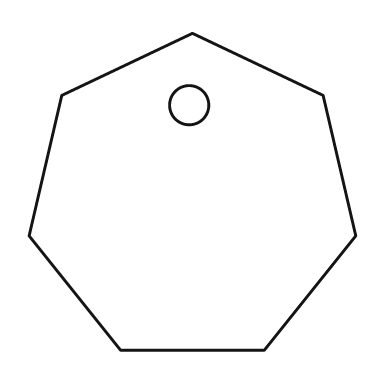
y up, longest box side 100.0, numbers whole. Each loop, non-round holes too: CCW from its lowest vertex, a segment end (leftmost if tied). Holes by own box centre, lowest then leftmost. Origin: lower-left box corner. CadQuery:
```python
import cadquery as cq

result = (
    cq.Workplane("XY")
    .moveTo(28.0, 0.0)
    .lineTo(72.0, 0.0)
    .lineTo(100.0, 35.0)
    .lineTo(90.0, 78.0)
    .lineTo(50.0, 97.0)
    .lineTo(10.0, 78.0)
    .lineTo(0.0, 35.0)
    .close()
    .moveTo(49.0, 75.0)
    .circle(6.0)
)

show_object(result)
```